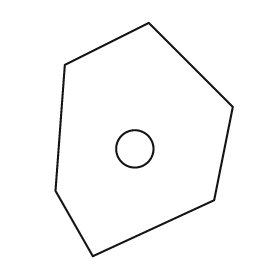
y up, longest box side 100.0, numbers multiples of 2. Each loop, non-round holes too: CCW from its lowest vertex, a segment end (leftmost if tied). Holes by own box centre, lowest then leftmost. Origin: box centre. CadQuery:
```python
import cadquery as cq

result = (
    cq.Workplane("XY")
    .moveTo(-22.0, -50.0)
    .lineTo(30.0, -26.0)
    .lineTo(38.0, 14.0)
    .lineTo(2.0, 50.0)
    .lineTo(-34.0, 32.0)
    .lineTo(-38.0, -22.0)
    .close()
    .moveTo(-4.0, -4.0)
    .circle(8.0)
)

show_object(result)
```